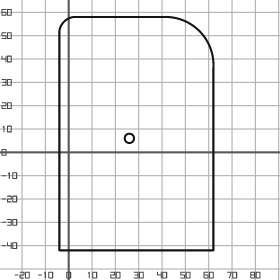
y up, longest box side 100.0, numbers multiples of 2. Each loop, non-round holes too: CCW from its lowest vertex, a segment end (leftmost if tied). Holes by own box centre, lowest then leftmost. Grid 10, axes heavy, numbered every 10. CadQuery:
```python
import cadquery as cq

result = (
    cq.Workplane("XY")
    .moveTo(-4.0, -42.0)
    .lineTo(62.0, -42.0)
    .lineTo(62.0, 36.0)
    .threePointArc((56.0, 52.0), (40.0, 58.0))
    .lineTo(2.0, 58.0)
    .threePointArc((-2.0, 56.0), (-4.0, 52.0))
    .close()
    .moveTo(26.0, 6.0)
    .circle(2.0)
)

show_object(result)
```